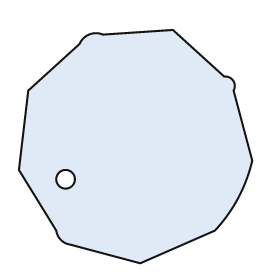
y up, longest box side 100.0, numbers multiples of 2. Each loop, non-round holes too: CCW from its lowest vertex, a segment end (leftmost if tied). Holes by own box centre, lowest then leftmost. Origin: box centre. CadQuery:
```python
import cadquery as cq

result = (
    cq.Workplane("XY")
    .moveTo(2.0, -50.0)
    .lineTo(34.0, -36.0)
    .threePointArc((44.0, -22.0), (50.0, -6.0))
    .lineTo(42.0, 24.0)
    .threePointArc((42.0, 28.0), (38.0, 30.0))
    .lineTo(16.0, 50.0)
    .lineTo(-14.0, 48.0)
    .threePointArc((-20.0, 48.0), (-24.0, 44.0))
    .lineTo(-46.0, 24.0)
    .lineTo(-50.0, -10.0)
    .lineTo(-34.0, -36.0)
    .threePointArc((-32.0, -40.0), (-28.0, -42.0))
    .close()
    .moveTo(-30.0, -14.0)
    .circle(4.0)
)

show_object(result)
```